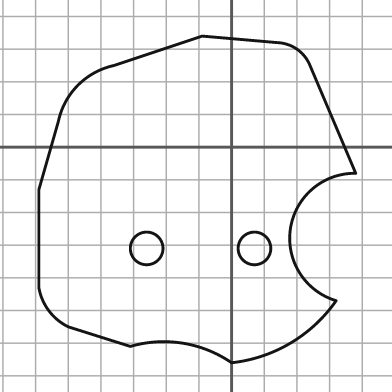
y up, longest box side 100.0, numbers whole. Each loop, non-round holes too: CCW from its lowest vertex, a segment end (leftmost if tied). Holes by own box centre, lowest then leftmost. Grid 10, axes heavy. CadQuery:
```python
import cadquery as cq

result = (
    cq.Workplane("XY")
    .moveTo(0.0, -66.0)
    .threePointArc((18.0, -60.0), (32.0, -47.0))
    .threePointArc((18.0, -25.0), (38.0, -8.0))
    .lineTo(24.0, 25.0)
    .threePointArc((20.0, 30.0), (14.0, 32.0))
    .lineTo(-9.0, 34.0)
    .lineTo(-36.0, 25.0)
    .threePointArc((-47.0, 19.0), (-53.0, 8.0))
    .lineTo(-59.0, -13.0)
    .lineTo(-59.0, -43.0)
    .threePointArc((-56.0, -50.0), (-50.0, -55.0))
    .lineTo(-31.0, -61.0)
    .threePointArc((-15.0, -60.0), (0.0, -66.0))
    .close()
    .moveTo(-26.0, -31.0)
    .circle(5.0)
    .moveTo(7.0, -31.0)
    .circle(5.0)
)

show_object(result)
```